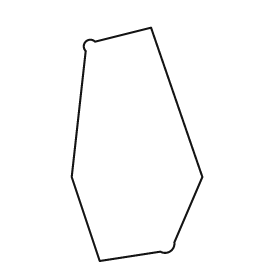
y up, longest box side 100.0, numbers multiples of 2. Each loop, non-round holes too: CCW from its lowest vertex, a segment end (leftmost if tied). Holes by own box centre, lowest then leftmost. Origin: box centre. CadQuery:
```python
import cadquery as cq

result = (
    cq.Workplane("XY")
    .moveTo(-16.0, -50.0)
    .lineTo(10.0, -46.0)
    .threePointArc((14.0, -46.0), (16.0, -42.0))
    .lineTo(28.0, -14.0)
    .lineTo(6.0, 50.0)
    .lineTo(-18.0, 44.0)
    .threePointArc((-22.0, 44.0), (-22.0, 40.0))
    .lineTo(-28.0, -14.0)
    .close()
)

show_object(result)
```